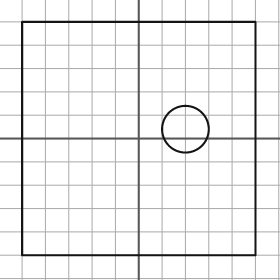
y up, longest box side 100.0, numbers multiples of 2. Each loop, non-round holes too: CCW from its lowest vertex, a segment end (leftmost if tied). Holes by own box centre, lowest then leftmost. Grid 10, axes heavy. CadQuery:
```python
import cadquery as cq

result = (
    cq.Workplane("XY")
    .moveTo(-50.0, -50.0)
    .lineTo(50.0, -50.0)
    .lineTo(50.0, 50.0)
    .lineTo(-50.0, 50.0)
    .close()
    .moveTo(20.0, 4.0)
    .circle(10.0)
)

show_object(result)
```